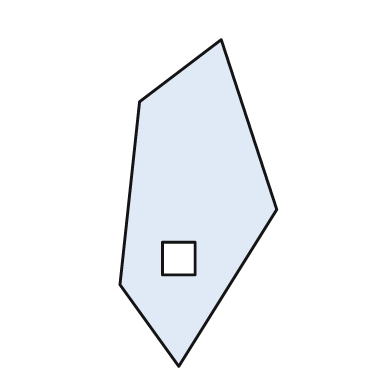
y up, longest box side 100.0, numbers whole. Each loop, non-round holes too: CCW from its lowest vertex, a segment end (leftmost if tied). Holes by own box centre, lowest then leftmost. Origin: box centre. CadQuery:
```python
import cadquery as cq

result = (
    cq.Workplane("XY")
    .moveTo(-6.0, -50.0)
    .lineTo(24.0, -2.0)
    .lineTo(7.0, 50.0)
    .lineTo(-18.0, 31.0)
    .lineTo(-24.0, -25.0)
    .close()
    .moveTo(-11.0, -22.0)
    .lineTo(-1.0, -22.0)
    .lineTo(-1.0, -12.0)
    .lineTo(-11.0, -12.0)
    .close()
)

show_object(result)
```